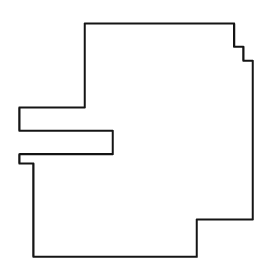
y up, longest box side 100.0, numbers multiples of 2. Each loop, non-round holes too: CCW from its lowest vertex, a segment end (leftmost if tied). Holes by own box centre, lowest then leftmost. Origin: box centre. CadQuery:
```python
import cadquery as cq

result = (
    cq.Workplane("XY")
    .moveTo(-44.0, -50.0)
    .lineTo(26.0, -50.0)
    .lineTo(26.0, -34.0)
    .lineTo(50.0, -34.0)
    .lineTo(50.0, 34.0)
    .lineTo(46.0, 34.0)
    .lineTo(46.0, 40.0)
    .lineTo(42.0, 40.0)
    .lineTo(42.0, 50.0)
    .lineTo(-22.0, 50.0)
    .lineTo(-22.0, 14.0)
    .lineTo(-50.0, 14.0)
    .lineTo(-50.0, 4.0)
    .lineTo(-10.0, 4.0)
    .lineTo(-10.0, -6.0)
    .lineTo(-50.0, -6.0)
    .lineTo(-50.0, -10.0)
    .lineTo(-44.0, -10.0)
    .close()
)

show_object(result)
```